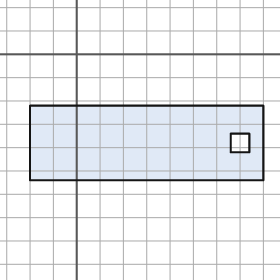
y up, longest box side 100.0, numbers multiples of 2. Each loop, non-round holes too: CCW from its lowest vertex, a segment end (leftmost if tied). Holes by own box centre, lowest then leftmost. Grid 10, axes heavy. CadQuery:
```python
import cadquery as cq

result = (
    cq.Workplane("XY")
    .moveTo(-20.0, -54.0)
    .lineTo(80.0, -54.0)
    .lineTo(80.0, -22.0)
    .lineTo(-20.0, -22.0)
    .close()
    .moveTo(66.0, -42.0)
    .lineTo(74.0, -42.0)
    .lineTo(74.0, -34.0)
    .lineTo(66.0, -34.0)
    .close()
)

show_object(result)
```